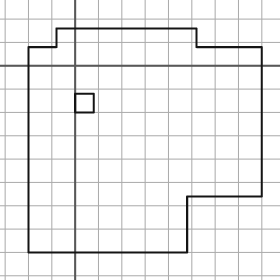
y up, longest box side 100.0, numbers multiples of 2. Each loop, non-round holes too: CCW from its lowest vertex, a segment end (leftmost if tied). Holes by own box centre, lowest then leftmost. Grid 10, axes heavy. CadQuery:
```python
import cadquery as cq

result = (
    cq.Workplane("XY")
    .moveTo(-20.0, -80.0)
    .lineTo(48.0, -80.0)
    .lineTo(48.0, -56.0)
    .lineTo(80.0, -56.0)
    .lineTo(80.0, 8.0)
    .lineTo(52.0, 8.0)
    .lineTo(52.0, 16.0)
    .lineTo(-8.0, 16.0)
    .lineTo(-8.0, 8.0)
    .lineTo(-20.0, 8.0)
    .close()
    .moveTo(0.0, -20.0)
    .lineTo(8.0, -20.0)
    .lineTo(8.0, -12.0)
    .lineTo(0.0, -12.0)
    .close()
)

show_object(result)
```